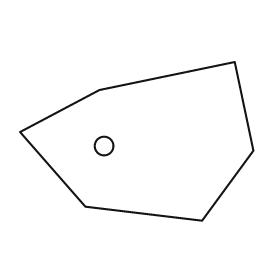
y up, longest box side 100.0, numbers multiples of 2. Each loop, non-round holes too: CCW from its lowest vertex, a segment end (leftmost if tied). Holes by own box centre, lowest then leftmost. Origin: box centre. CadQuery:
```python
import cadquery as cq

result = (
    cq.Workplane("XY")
    .moveTo(28.0, -34.0)
    .lineTo(50.0, -4.0)
    .lineTo(42.0, 34.0)
    .lineTo(-16.0, 22.0)
    .lineTo(-50.0, 4.0)
    .lineTo(-22.0, -28.0)
    .close()
    .moveTo(-14.0, -2.0)
    .circle(4.0)
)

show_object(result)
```